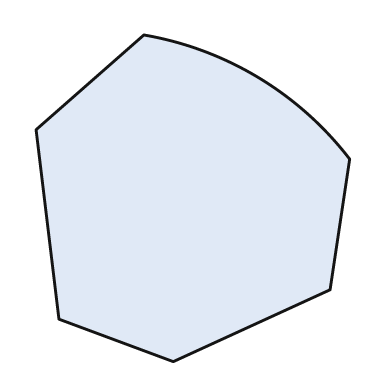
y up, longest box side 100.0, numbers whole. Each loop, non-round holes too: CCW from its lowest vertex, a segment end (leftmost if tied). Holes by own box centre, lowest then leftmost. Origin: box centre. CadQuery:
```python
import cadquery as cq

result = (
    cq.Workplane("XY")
    .moveTo(-6.0, -50.0)
    .lineTo(42.0, -28.0)
    .lineTo(48.0, 12.0)
    .threePointArc((20.0, 37.0), (-15.0, 50.0))
    .lineTo(-48.0, 21.0)
    .lineTo(-41.0, -37.0)
    .close()
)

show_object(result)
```